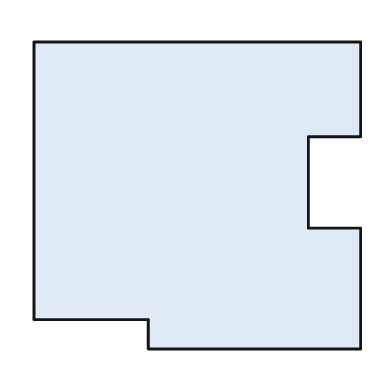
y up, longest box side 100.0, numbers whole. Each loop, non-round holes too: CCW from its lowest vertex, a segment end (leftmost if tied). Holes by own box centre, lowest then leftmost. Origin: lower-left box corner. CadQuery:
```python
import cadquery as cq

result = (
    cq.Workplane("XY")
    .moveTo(35.0, 0.0)
    .lineTo(100.0, 0.0)
    .lineTo(100.0, 37.0)
    .lineTo(84.0, 37.0)
    .lineTo(84.0, 65.0)
    .lineTo(100.0, 65.0)
    .lineTo(100.0, 94.0)
    .lineTo(0.0, 94.0)
    .lineTo(0.0, 9.0)
    .lineTo(35.0, 9.0)
    .close()
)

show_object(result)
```